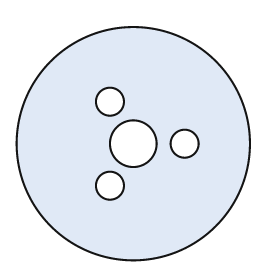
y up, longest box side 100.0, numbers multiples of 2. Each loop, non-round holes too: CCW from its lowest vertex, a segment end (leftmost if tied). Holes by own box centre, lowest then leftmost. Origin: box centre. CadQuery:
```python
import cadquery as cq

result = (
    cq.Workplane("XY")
    .moveTo(0.0, 0.0)
    .circle(50.0)
    .moveTo(-10.0, -18.0)
    .circle(6.0)
    .moveTo(0.0, 0.0)
    .circle(10.0)
    .moveTo(22.0, 0.0)
    .circle(6.0)
    .moveTo(-10.0, 18.0)
    .circle(6.0)
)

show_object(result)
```